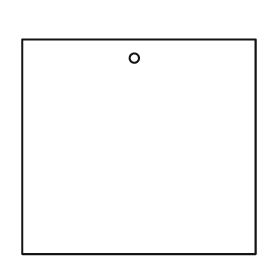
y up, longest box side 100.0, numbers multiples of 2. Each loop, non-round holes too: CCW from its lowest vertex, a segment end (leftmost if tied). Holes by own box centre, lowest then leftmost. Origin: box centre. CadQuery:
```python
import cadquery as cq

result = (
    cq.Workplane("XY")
    .moveTo(-50.0, -46.0)
    .lineTo(50.0, -46.0)
    .lineTo(50.0, 46.0)
    .lineTo(-50.0, 46.0)
    .close()
    .moveTo(-2.0, 38.0)
    .circle(2.0)
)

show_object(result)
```